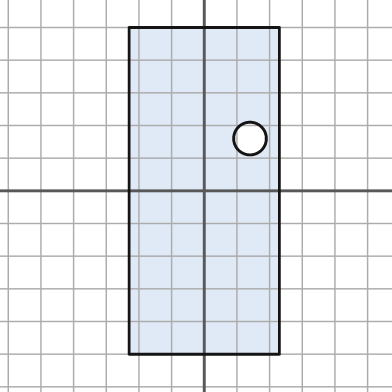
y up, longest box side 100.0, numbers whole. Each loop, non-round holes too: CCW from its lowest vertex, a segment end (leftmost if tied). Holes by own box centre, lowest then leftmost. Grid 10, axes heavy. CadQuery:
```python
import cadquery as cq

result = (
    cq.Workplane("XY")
    .moveTo(-23.0, -50.0)
    .lineTo(23.0, -50.0)
    .lineTo(23.0, 50.0)
    .lineTo(-23.0, 50.0)
    .close()
    .moveTo(14.0, 16.0)
    .circle(5.0)
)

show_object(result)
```